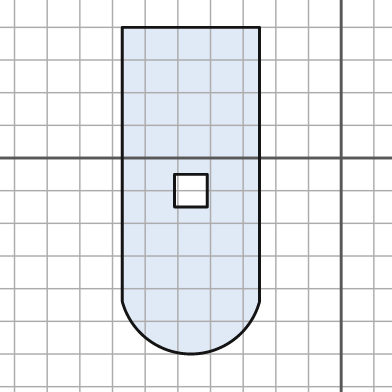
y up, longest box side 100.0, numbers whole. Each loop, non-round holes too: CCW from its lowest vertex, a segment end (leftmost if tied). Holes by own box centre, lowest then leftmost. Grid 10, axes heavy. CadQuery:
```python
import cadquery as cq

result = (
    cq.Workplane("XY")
    .moveTo(-67.0, -44.0)
    .threePointArc((-46.0, -60.0), (-25.0, -44.0))
    .lineTo(-25.0, 40.0)
    .lineTo(-67.0, 40.0)
    .close()
    .moveTo(-51.0, -15.0)
    .lineTo(-41.0, -15.0)
    .lineTo(-41.0, -5.0)
    .lineTo(-51.0, -5.0)
    .close()
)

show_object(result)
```